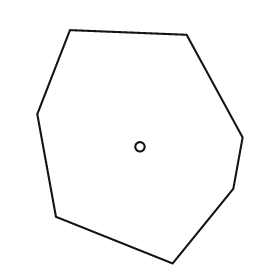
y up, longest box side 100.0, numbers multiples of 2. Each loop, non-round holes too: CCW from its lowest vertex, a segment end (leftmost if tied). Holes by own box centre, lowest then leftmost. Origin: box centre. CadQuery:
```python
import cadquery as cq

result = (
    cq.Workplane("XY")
    .moveTo(14.0, -50.0)
    .lineTo(40.0, -18.0)
    .lineTo(44.0, 4.0)
    .lineTo(20.0, 48.0)
    .lineTo(-30.0, 50.0)
    .lineTo(-44.0, 14.0)
    .lineTo(-36.0, -30.0)
    .close()
    .moveTo(0.0, 0.0)
    .circle(2.0)
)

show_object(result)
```